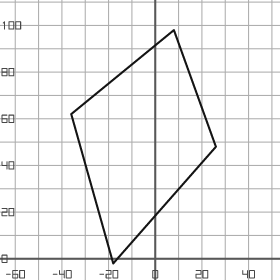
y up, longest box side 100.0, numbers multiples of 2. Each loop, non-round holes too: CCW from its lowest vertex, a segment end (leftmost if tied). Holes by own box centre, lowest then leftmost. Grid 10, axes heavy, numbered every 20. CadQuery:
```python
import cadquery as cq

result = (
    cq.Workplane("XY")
    .moveTo(-18.0, -2.0)
    .lineTo(26.0, 48.0)
    .lineTo(8.0, 98.0)
    .lineTo(-36.0, 62.0)
    .close()
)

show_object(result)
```